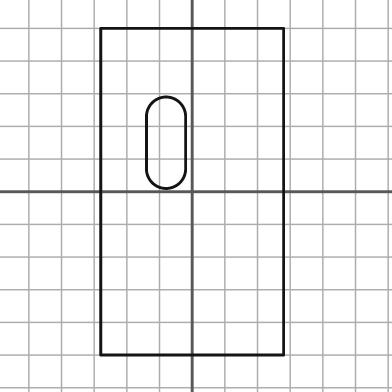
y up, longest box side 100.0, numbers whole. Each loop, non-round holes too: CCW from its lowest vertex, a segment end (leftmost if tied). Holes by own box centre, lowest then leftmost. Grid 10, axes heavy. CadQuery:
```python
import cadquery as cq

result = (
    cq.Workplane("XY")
    .moveTo(-28.0, -50.0)
    .lineTo(28.0, -50.0)
    .lineTo(28.0, 50.0)
    .lineTo(-28.0, 50.0)
    .close()
    .moveTo(-14.0, 7.0)
    .threePointArc((-8.0, 1.0), (-2.0, 7.0))
    .lineTo(-2.0, 23.0)
    .threePointArc((-8.0, 29.0), (-14.0, 23.0))
    .close()
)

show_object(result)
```